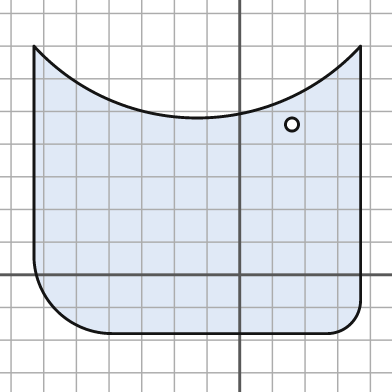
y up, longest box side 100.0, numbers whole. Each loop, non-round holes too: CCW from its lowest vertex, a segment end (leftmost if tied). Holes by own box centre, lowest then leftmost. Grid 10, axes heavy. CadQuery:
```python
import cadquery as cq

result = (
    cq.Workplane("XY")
    .moveTo(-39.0, -18.0)
    .lineTo(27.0, -18.0)
    .threePointArc((34.0, -15.0), (37.0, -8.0))
    .lineTo(37.0, 70.0)
    .threePointArc((-13.0, 48.0), (-63.0, 70.0))
    .lineTo(-63.0, 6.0)
    .threePointArc((-56.0, -11.0), (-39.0, -18.0))
    .close()
    .moveTo(16.0, 46.0)
    .circle(2.0)
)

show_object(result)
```